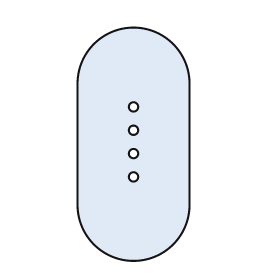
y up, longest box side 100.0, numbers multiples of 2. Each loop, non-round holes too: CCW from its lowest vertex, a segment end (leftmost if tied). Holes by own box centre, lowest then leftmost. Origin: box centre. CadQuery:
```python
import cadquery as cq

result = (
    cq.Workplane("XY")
    .moveTo(-24.0, -26.0)
    .threePointArc((0.0, -50.0), (24.0, -26.0))
    .lineTo(24.0, 26.0)
    .threePointArc((0.0, 50.0), (-24.0, 26.0))
    .close()
    .moveTo(0.0, -14.0)
    .circle(2.0)
    .moveTo(0.0, -4.0)
    .circle(2.0)
    .moveTo(0.0, 6.0)
    .circle(2.0)
    .moveTo(0.0, 16.0)
    .circle(2.0)
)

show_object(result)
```